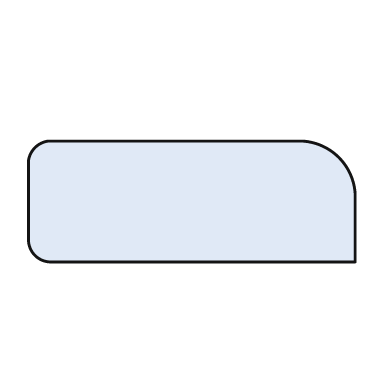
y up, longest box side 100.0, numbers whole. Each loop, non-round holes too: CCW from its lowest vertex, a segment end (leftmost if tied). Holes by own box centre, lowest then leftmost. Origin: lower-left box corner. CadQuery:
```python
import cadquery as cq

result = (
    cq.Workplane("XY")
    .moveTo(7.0, 0.0)
    .lineTo(100.0, 0.0)
    .lineTo(100.0, 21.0)
    .threePointArc((95.0, 32.0), (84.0, 37.0))
    .lineTo(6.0, 37.0)
    .threePointArc((2.0, 35.0), (0.0, 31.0))
    .lineTo(0.0, 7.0)
    .threePointArc((2.0, 2.0), (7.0, 0.0))
    .close()
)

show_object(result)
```